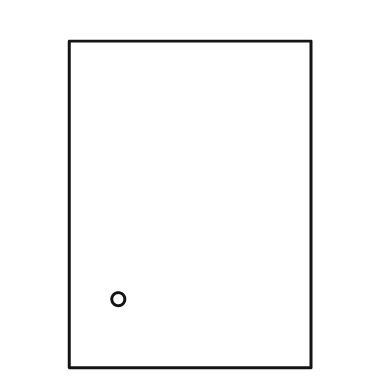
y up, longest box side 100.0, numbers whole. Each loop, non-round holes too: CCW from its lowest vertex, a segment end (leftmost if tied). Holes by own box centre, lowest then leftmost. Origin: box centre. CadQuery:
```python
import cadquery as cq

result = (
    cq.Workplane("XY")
    .moveTo(-37.0, -50.0)
    .lineTo(37.0, -50.0)
    .lineTo(37.0, 50.0)
    .lineTo(-37.0, 50.0)
    .close()
    .moveTo(-22.0, -29.0)
    .circle(2.0)
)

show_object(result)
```